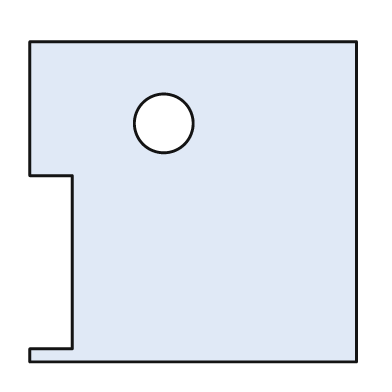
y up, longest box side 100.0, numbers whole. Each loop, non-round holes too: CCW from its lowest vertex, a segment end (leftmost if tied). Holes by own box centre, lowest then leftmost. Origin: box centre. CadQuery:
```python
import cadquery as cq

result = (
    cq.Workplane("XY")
    .moveTo(-50.0, -49.0)
    .lineTo(50.0, -49.0)
    .lineTo(50.0, 49.0)
    .lineTo(-50.0, 49.0)
    .lineTo(-50.0, 8.0)
    .lineTo(-37.0, 8.0)
    .lineTo(-37.0, -45.0)
    .lineTo(-50.0, -45.0)
    .close()
    .moveTo(-9.0, 24.0)
    .circle(9.0)
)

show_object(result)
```